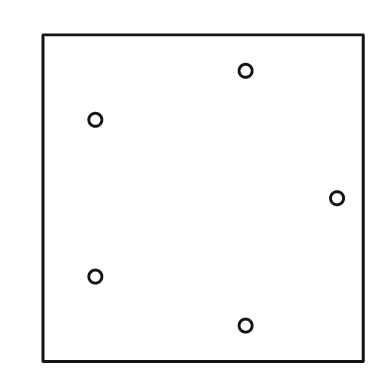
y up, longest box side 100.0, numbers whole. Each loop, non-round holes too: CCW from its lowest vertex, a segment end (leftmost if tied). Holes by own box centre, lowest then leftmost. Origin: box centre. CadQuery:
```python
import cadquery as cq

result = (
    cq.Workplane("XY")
    .moveTo(-49.0, -50.0)
    .lineTo(49.0, -50.0)
    .lineTo(49.0, 50.0)
    .lineTo(-49.0, 50.0)
    .close()
    .moveTo(13.0, -39.0)
    .circle(2.0)
    .moveTo(-33.0, -24.0)
    .circle(2.0)
    .moveTo(41.0, 0.0)
    .circle(2.0)
    .moveTo(-33.0, 24.0)
    .circle(2.0)
    .moveTo(13.0, 39.0)
    .circle(2.0)
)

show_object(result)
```